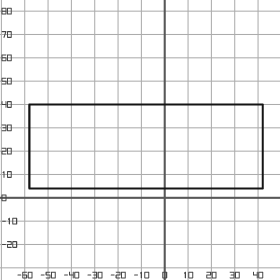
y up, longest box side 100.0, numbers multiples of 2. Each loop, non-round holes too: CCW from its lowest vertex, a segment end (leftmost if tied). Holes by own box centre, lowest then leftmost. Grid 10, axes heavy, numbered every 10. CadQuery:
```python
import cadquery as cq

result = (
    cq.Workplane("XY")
    .moveTo(-58.0, 4.0)
    .lineTo(42.0, 4.0)
    .lineTo(42.0, 40.0)
    .lineTo(-58.0, 40.0)
    .close()
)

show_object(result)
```